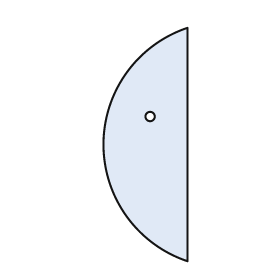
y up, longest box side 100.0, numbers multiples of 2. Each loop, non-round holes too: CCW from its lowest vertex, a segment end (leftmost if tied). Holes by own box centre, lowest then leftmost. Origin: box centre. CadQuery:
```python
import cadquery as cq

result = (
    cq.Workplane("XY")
    .moveTo(18.0, -50.0)
    .lineTo(18.0, 50.0)
    .threePointArc((-18.0, 0.0), (18.0, -50.0))
    .close()
    .moveTo(2.0, 12.0)
    .circle(2.0)
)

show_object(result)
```